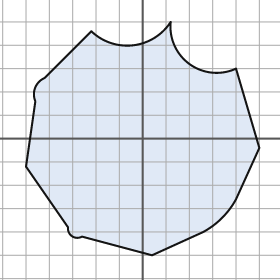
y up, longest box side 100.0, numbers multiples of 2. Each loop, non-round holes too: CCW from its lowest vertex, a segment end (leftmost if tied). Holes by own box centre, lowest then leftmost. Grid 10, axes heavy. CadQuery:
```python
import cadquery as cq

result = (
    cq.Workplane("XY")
    .moveTo(4.0, -50.0)
    .lineTo(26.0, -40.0)
    .threePointArc((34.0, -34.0), (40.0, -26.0))
    .lineTo(50.0, -4.0)
    .lineTo(40.0, 30.0)
    .threePointArc((20.0, 32.0), (12.0, 50.0))
    .threePointArc((-4.0, 40.0), (-22.0, 46.0))
    .lineTo(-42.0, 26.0)
    .threePointArc((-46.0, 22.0), (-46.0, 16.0))
    .lineTo(-50.0, -12.0)
    .lineTo(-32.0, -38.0)
    .threePointArc((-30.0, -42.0), (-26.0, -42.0))
    .close()
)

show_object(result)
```